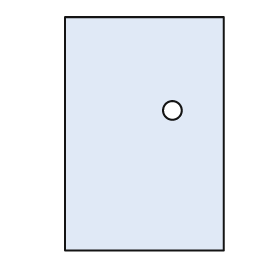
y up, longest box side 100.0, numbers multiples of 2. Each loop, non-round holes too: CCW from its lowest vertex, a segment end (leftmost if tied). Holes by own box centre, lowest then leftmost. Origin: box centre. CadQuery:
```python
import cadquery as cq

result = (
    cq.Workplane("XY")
    .moveTo(-34.0, -50.0)
    .lineTo(34.0, -50.0)
    .lineTo(34.0, 50.0)
    .lineTo(-34.0, 50.0)
    .close()
    .moveTo(12.0, 10.0)
    .circle(4.0)
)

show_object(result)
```